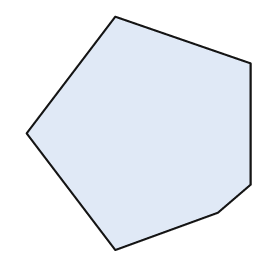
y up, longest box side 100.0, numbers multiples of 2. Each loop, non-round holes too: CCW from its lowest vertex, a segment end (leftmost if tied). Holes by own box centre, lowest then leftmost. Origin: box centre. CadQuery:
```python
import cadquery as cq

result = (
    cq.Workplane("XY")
    .moveTo(-10.0, -50.0)
    .lineTo(34.0, -34.0)
    .lineTo(48.0, -22.0)
    .lineTo(48.0, 30.0)
    .lineTo(-10.0, 50.0)
    .lineTo(-48.0, 0.0)
    .close()
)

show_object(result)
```